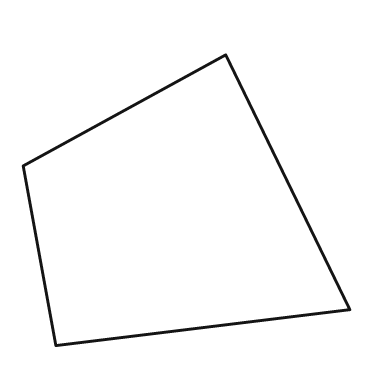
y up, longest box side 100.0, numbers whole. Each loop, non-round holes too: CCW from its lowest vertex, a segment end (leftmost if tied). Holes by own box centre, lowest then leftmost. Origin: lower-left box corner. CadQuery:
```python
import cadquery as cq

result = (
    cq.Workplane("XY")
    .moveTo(10.0, 0.0)
    .lineTo(100.0, 11.0)
    .lineTo(62.0, 89.0)
    .lineTo(0.0, 55.0)
    .close()
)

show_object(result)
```